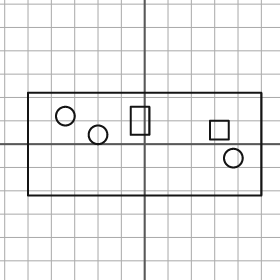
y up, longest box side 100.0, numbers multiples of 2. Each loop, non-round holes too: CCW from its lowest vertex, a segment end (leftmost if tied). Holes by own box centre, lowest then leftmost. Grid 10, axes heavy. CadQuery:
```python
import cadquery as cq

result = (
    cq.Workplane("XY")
    .moveTo(-50.0, -22.0)
    .lineTo(50.0, -22.0)
    .lineTo(50.0, 22.0)
    .lineTo(-50.0, 22.0)
    .close()
    .moveTo(38.0, -6.0)
    .circle(4.0)
    .moveTo(-20.0, 4.0)
    .circle(4.0)
    .moveTo(28.0, 2.0)
    .lineTo(36.0, 2.0)
    .lineTo(36.0, 10.0)
    .lineTo(28.0, 10.0)
    .close()
    .moveTo(-6.0, 4.0)
    .lineTo(2.0, 4.0)
    .lineTo(2.0, 16.0)
    .lineTo(-6.0, 16.0)
    .close()
    .moveTo(-34.0, 12.0)
    .circle(4.0)
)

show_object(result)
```